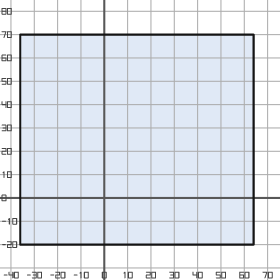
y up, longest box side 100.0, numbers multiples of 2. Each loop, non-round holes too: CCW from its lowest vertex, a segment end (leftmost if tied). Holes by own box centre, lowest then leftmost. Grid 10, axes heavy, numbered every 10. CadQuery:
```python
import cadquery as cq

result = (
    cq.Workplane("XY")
    .moveTo(-36.0, -20.0)
    .lineTo(64.0, -20.0)
    .lineTo(64.0, 70.0)
    .lineTo(-36.0, 70.0)
    .close()
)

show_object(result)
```